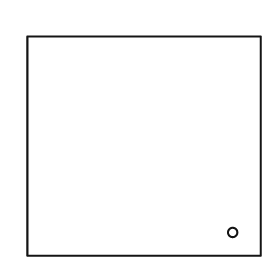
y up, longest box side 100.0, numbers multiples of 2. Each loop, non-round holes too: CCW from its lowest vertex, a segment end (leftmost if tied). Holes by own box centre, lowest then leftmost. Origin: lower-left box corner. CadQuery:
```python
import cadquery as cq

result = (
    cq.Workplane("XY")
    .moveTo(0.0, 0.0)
    .lineTo(100.0, 0.0)
    .lineTo(100.0, 94.0)
    .lineTo(0.0, 94.0)
    .close()
    .moveTo(88.0, 10.0)
    .circle(2.0)
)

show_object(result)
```